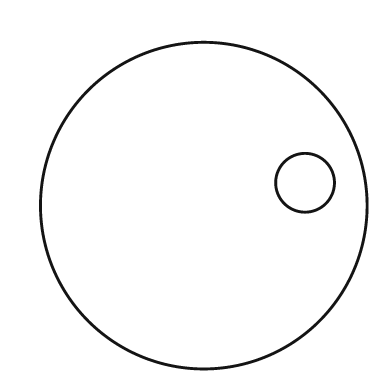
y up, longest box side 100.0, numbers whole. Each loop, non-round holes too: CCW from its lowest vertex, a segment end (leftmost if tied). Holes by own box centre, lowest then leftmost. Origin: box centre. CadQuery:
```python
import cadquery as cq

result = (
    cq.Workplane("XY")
    .moveTo(0.0, 0.0)
    .circle(50.0)
    .moveTo(31.0, 7.0)
    .circle(9.0)
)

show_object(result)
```